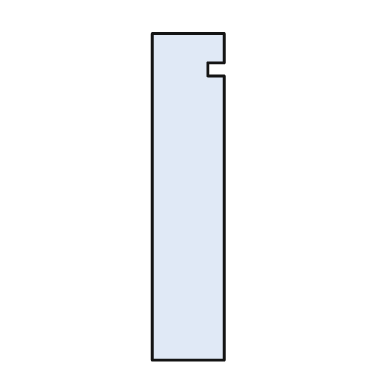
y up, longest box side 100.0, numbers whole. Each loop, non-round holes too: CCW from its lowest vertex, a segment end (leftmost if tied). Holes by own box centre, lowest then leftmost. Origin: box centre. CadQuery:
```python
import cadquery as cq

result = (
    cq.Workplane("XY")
    .moveTo(-11.0, -50.0)
    .lineTo(11.0, -50.0)
    .lineTo(11.0, 37.0)
    .lineTo(6.0, 37.0)
    .lineTo(6.0, 41.0)
    .lineTo(11.0, 41.0)
    .lineTo(11.0, 50.0)
    .lineTo(-11.0, 50.0)
    .close()
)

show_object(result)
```